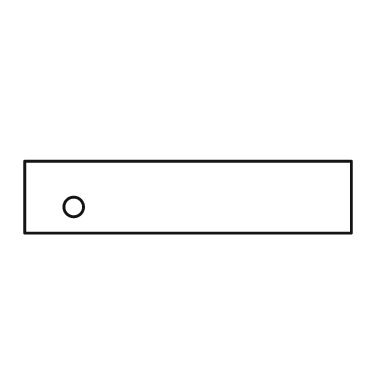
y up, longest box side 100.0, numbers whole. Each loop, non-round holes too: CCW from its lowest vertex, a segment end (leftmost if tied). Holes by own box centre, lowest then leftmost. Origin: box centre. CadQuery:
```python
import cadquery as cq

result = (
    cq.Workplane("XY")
    .moveTo(-50.0, -11.0)
    .lineTo(50.0, -11.0)
    .lineTo(50.0, 11.0)
    .lineTo(-50.0, 11.0)
    .close()
    .moveTo(-35.0, -3.0)
    .circle(3.0)
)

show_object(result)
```